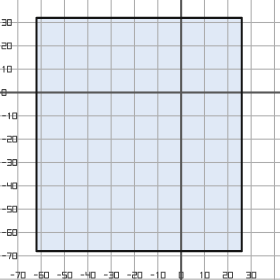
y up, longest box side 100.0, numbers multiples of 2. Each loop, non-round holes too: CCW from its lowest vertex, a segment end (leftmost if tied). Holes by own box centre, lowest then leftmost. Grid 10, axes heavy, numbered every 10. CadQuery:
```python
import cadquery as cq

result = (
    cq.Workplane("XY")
    .moveTo(-62.0, -68.0)
    .lineTo(26.0, -68.0)
    .lineTo(26.0, 32.0)
    .lineTo(-62.0, 32.0)
    .close()
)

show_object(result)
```